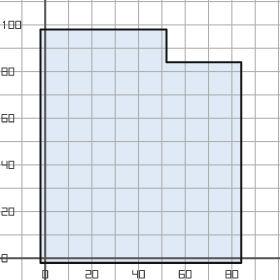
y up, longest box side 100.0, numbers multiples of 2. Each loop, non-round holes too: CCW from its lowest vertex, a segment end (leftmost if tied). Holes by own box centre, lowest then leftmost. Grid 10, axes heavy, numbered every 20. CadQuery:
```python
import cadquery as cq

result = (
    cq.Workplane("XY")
    .moveTo(-2.0, -2.0)
    .lineTo(84.0, -2.0)
    .lineTo(84.0, 84.0)
    .lineTo(52.0, 84.0)
    .lineTo(52.0, 98.0)
    .lineTo(-2.0, 98.0)
    .close()
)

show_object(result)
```